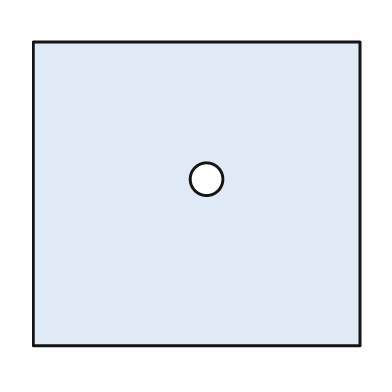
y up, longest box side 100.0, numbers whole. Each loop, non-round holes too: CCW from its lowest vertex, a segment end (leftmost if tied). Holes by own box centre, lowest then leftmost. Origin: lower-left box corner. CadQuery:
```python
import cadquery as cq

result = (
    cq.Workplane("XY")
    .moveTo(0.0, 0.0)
    .lineTo(100.0, 0.0)
    .lineTo(100.0, 93.0)
    .lineTo(0.0, 93.0)
    .close()
    .moveTo(53.0, 51.0)
    .circle(5.0)
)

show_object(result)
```